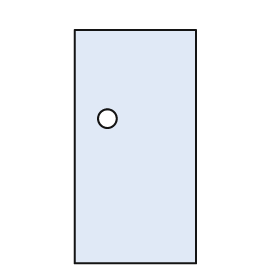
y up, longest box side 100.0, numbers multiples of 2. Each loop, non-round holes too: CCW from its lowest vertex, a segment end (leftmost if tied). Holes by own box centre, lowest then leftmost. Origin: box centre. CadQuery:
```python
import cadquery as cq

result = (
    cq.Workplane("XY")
    .moveTo(-26.0, -50.0)
    .lineTo(26.0, -50.0)
    .lineTo(26.0, 50.0)
    .lineTo(-26.0, 50.0)
    .close()
    .moveTo(-12.0, 12.0)
    .circle(4.0)
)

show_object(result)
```